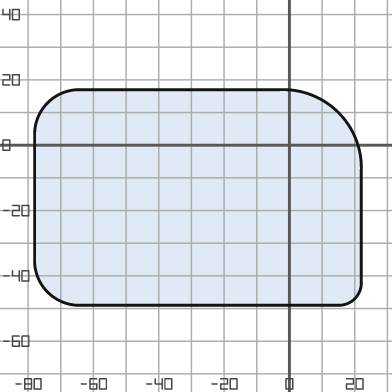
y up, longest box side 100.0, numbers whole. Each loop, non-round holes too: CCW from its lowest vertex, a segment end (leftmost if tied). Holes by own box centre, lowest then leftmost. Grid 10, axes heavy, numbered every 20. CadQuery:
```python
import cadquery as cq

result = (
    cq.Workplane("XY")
    .moveTo(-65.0, -49.0)
    .lineTo(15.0, -49.0)
    .threePointArc((20.0, -47.0), (22.0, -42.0))
    .lineTo(22.0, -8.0)
    .threePointArc((15.0, 10.0), (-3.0, 17.0))
    .lineTo(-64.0, 17.0)
    .threePointArc((-74.0, 13.0), (-78.0, 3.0))
    .lineTo(-78.0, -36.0)
    .threePointArc((-74.0, -45.0), (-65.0, -49.0))
    .close()
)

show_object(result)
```